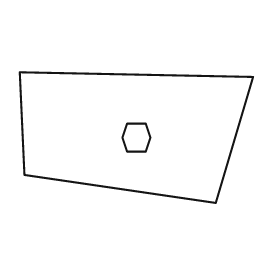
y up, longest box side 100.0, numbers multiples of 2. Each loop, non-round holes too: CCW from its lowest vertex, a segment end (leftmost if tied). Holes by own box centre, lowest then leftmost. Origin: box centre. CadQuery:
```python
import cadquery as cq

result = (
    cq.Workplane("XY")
    .moveTo(34.0, -28.0)
    .lineTo(50.0, 26.0)
    .lineTo(-50.0, 28.0)
    .lineTo(-48.0, -16.0)
    .close()
    .moveTo(-4.0, -6.0)
    .lineTo(4.0, -6.0)
    .lineTo(6.0, 0.0)
    .lineTo(4.0, 6.0)
    .lineTo(-4.0, 6.0)
    .lineTo(-6.0, 0.0)
    .close()
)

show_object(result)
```